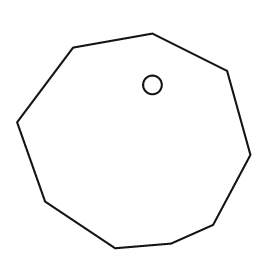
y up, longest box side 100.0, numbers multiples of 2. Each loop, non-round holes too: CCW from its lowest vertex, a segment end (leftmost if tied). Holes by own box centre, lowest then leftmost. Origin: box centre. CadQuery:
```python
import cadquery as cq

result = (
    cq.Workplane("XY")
    .moveTo(-8.0, -46.0)
    .lineTo(16.0, -44.0)
    .lineTo(34.0, -36.0)
    .lineTo(50.0, -6.0)
    .lineTo(40.0, 30.0)
    .lineTo(8.0, 46.0)
    .lineTo(-26.0, 40.0)
    .lineTo(-50.0, 8.0)
    .lineTo(-38.0, -26.0)
    .close()
    .moveTo(8.0, 24.0)
    .circle(4.0)
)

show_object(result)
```